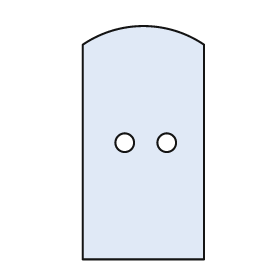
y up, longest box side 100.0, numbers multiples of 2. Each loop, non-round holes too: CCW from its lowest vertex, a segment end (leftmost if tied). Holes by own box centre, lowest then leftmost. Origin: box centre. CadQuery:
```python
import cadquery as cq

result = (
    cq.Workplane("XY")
    .moveTo(-26.0, -50.0)
    .lineTo(26.0, -50.0)
    .lineTo(26.0, 42.0)
    .threePointArc((0.0, 50.0), (-26.0, 42.0))
    .close()
    .moveTo(-8.0, 0.0)
    .circle(4.0)
    .moveTo(10.0, 0.0)
    .circle(4.0)
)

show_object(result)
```